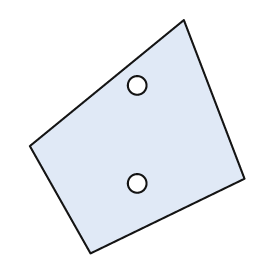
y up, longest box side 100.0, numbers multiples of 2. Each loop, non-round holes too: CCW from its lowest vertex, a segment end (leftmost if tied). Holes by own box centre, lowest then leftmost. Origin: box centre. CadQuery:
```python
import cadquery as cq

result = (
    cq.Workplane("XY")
    .moveTo(-20.0, -50.0)
    .lineTo(46.0, -18.0)
    .lineTo(20.0, 50.0)
    .lineTo(-46.0, -4.0)
    .close()
    .moveTo(0.0, -20.0)
    .circle(4.0)
    .moveTo(0.0, 22.0)
    .circle(4.0)
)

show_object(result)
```